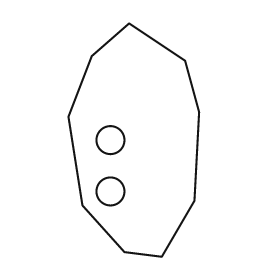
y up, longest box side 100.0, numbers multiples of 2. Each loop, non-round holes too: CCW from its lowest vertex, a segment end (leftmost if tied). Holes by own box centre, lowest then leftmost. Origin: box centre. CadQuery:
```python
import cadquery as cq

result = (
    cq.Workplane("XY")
    .moveTo(12.0, -50.0)
    .lineTo(26.0, -26.0)
    .lineTo(28.0, 12.0)
    .lineTo(22.0, 34.0)
    .lineTo(-2.0, 50.0)
    .lineTo(-18.0, 36.0)
    .lineTo(-28.0, 10.0)
    .lineTo(-22.0, -28.0)
    .lineTo(-4.0, -48.0)
    .close()
    .moveTo(-10.0, -22.0)
    .circle(6.0)
    .moveTo(-10.0, 0.0)
    .circle(6.0)
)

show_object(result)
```